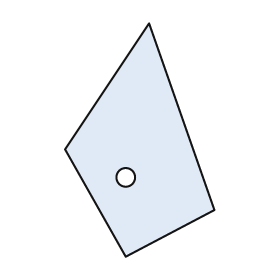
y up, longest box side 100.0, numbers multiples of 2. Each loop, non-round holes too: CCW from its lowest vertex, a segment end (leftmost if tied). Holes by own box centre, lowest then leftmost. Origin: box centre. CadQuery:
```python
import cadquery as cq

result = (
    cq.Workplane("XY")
    .moveTo(-6.0, -50.0)
    .lineTo(32.0, -30.0)
    .lineTo(4.0, 50.0)
    .lineTo(-32.0, -4.0)
    .close()
    .moveTo(-6.0, -16.0)
    .circle(4.0)
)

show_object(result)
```